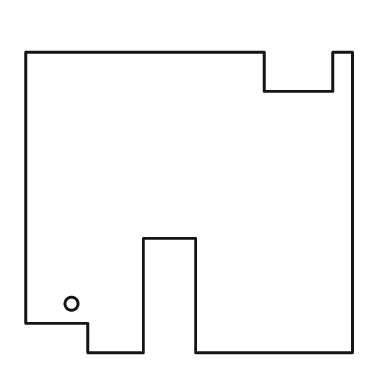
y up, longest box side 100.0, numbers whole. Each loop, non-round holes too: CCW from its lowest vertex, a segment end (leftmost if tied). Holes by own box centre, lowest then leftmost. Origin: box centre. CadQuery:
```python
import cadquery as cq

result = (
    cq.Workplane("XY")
    .moveTo(-31.0, -46.0)
    .lineTo(-14.0, -46.0)
    .lineTo(-14.0, -11.0)
    .lineTo(2.0, -11.0)
    .lineTo(2.0, -46.0)
    .lineTo(50.0, -46.0)
    .lineTo(50.0, 46.0)
    .lineTo(44.0, 46.0)
    .lineTo(44.0, 34.0)
    .lineTo(23.0, 34.0)
    .lineTo(23.0, 46.0)
    .lineTo(-50.0, 46.0)
    .lineTo(-50.0, -37.0)
    .lineTo(-31.0, -37.0)
    .close()
    .moveTo(-36.0, -31.0)
    .circle(2.0)
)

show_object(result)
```